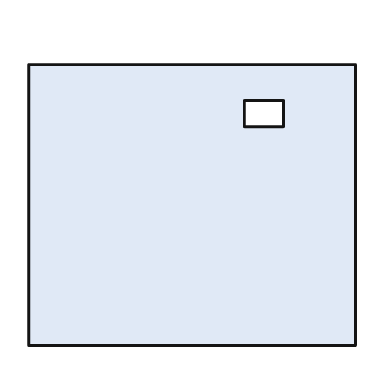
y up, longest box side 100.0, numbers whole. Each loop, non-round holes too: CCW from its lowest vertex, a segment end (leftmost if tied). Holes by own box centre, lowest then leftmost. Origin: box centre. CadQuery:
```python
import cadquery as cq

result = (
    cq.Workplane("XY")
    .moveTo(-50.0, -43.0)
    .lineTo(50.0, -43.0)
    .lineTo(50.0, 43.0)
    .lineTo(-50.0, 43.0)
    .close()
    .moveTo(16.0, 24.0)
    .lineTo(28.0, 24.0)
    .lineTo(28.0, 32.0)
    .lineTo(16.0, 32.0)
    .close()
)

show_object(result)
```